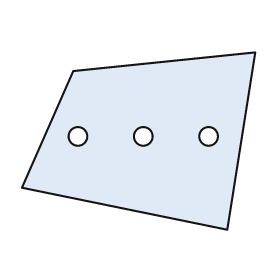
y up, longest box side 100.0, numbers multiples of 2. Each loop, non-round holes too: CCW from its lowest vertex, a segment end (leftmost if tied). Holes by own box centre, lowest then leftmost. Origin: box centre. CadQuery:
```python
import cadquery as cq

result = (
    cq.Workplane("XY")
    .moveTo(38.0, -38.0)
    .lineTo(50.0, 38.0)
    .lineTo(-28.0, 30.0)
    .lineTo(-50.0, -20.0)
    .close()
    .moveTo(-26.0, 2.0)
    .circle(4.0)
    .moveTo(2.0, 2.0)
    .circle(4.0)
    .moveTo(30.0, 2.0)
    .circle(4.0)
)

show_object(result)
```